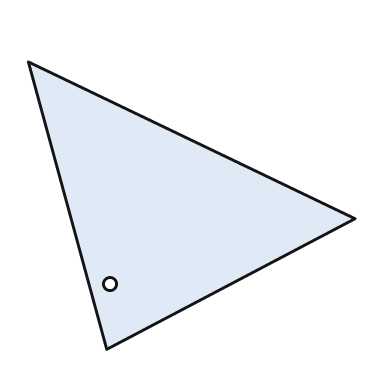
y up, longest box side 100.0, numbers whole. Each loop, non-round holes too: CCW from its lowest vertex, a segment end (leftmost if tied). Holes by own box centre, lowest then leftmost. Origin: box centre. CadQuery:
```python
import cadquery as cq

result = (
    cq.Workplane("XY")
    .moveTo(-26.0, -44.0)
    .lineTo(50.0, -4.0)
    .lineTo(-50.0, 44.0)
    .close()
    .moveTo(-25.0, -24.0)
    .circle(2.0)
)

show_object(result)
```